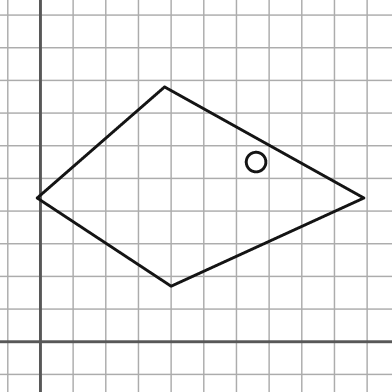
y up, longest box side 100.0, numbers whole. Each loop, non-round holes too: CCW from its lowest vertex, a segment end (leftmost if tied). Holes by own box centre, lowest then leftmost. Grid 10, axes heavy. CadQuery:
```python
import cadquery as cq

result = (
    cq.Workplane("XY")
    .moveTo(40.0, 17.0)
    .lineTo(99.0, 44.0)
    .lineTo(38.0, 78.0)
    .lineTo(-1.0, 44.0)
    .close()
    .moveTo(66.0, 55.0)
    .circle(3.0)
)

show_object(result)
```